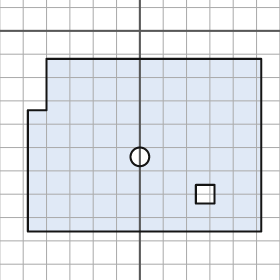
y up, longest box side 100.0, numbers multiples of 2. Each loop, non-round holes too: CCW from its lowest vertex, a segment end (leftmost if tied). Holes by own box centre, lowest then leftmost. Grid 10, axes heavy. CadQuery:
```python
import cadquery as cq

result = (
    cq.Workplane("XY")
    .moveTo(-48.0, -86.0)
    .lineTo(52.0, -86.0)
    .lineTo(52.0, -12.0)
    .lineTo(-40.0, -12.0)
    .lineTo(-40.0, -34.0)
    .lineTo(-48.0, -34.0)
    .close()
    .moveTo(24.0, -74.0)
    .lineTo(32.0, -74.0)
    .lineTo(32.0, -66.0)
    .lineTo(24.0, -66.0)
    .close()
    .moveTo(0.0, -54.0)
    .circle(4.0)
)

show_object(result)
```